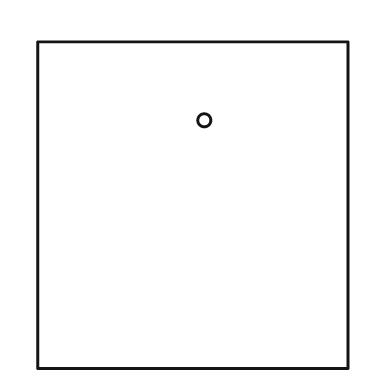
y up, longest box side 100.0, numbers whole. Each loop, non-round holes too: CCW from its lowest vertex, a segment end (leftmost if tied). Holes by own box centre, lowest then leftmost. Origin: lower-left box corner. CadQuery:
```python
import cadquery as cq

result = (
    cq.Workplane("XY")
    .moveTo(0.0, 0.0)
    .lineTo(95.0, 0.0)
    .lineTo(95.0, 100.0)
    .lineTo(0.0, 100.0)
    .close()
    .moveTo(51.0, 76.0)
    .circle(2.0)
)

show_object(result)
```